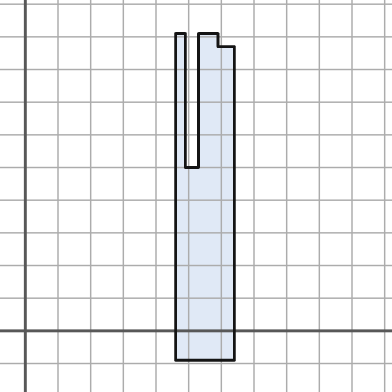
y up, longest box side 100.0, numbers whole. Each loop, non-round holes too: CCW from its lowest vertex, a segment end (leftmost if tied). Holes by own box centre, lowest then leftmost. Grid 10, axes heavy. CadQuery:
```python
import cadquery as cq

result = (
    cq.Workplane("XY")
    .moveTo(46.0, -9.0)
    .lineTo(64.0, -9.0)
    .lineTo(64.0, 87.0)
    .lineTo(59.0, 87.0)
    .lineTo(59.0, 91.0)
    .lineTo(53.0, 91.0)
    .lineTo(53.0, 50.0)
    .lineTo(49.0, 50.0)
    .lineTo(49.0, 91.0)
    .lineTo(46.0, 91.0)
    .close()
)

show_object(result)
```